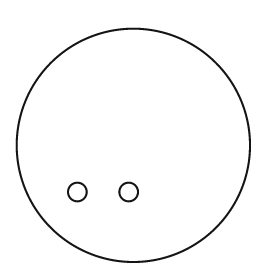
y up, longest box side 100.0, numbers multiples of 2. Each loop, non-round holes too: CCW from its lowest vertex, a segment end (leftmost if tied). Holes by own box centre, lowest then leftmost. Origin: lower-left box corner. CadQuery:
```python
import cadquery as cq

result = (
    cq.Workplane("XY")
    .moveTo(50.0, 50.0)
    .circle(50.0)
    .moveTo(26.0, 30.0)
    .circle(4.0)
    .moveTo(48.0, 30.0)
    .circle(4.0)
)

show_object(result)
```